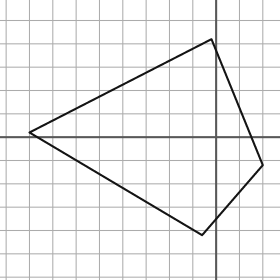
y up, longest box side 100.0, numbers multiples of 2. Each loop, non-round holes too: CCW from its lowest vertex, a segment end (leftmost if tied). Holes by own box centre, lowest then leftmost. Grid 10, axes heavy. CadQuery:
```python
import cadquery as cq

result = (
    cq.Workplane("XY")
    .moveTo(-6.0, -42.0)
    .lineTo(20.0, -12.0)
    .lineTo(-2.0, 42.0)
    .lineTo(-80.0, 2.0)
    .close()
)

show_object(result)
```